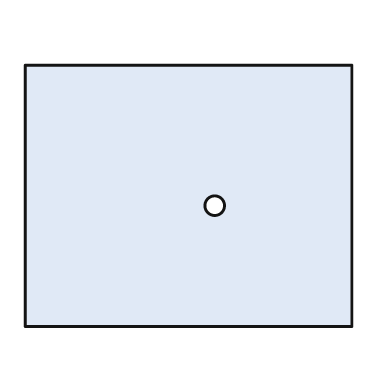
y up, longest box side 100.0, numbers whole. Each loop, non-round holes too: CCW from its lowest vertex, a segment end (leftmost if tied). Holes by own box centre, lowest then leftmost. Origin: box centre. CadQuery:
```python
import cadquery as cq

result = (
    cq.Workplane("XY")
    .moveTo(-50.0, -40.0)
    .lineTo(50.0, -40.0)
    .lineTo(50.0, 40.0)
    .lineTo(-50.0, 40.0)
    .close()
    .moveTo(8.0, -3.0)
    .circle(3.0)
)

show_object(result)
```